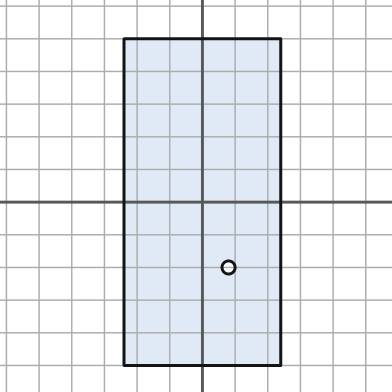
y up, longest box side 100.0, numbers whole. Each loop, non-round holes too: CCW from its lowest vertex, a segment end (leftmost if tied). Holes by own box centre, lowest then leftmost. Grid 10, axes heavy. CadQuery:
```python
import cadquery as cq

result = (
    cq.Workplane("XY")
    .moveTo(-24.0, -50.0)
    .lineTo(24.0, -50.0)
    .lineTo(24.0, 50.0)
    .lineTo(-24.0, 50.0)
    .close()
    .moveTo(8.0, -20.0)
    .circle(2.0)
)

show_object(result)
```